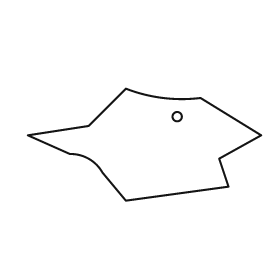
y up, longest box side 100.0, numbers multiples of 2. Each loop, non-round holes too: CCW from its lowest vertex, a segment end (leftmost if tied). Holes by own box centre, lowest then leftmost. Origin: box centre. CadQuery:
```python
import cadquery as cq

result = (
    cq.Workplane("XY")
    .moveTo(-8.0, -24.0)
    .lineTo(36.0, -18.0)
    .lineTo(32.0, -6.0)
    .lineTo(50.0, 4.0)
    .lineTo(24.0, 20.0)
    .threePointArc((8.0, 20.0), (-8.0, 24.0))
    .lineTo(-24.0, 8.0)
    .lineTo(-50.0, 4.0)
    .lineTo(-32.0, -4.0)
    .threePointArc((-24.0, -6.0), (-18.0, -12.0))
    .close()
    .moveTo(14.0, 12.0)
    .circle(2.0)
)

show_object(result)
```